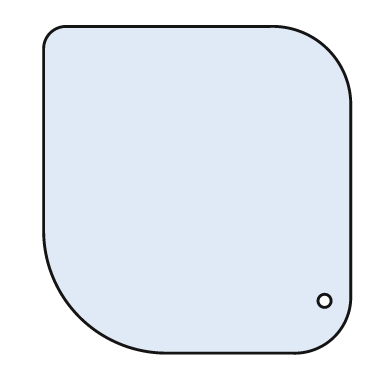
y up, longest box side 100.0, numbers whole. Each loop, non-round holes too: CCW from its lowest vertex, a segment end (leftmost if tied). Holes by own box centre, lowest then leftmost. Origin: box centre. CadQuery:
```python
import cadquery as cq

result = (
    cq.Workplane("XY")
    .moveTo(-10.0, -50.0)
    .lineTo(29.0, -50.0)
    .threePointArc((42.0, -45.0), (47.0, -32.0))
    .lineTo(47.0, 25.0)
    .threePointArc((40.0, 43.0), (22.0, 50.0))
    .lineTo(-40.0, 50.0)
    .threePointArc((-45.0, 48.0), (-47.0, 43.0))
    .lineTo(-47.0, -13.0)
    .threePointArc((-36.0, -39.0), (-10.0, -50.0))
    .close()
    .moveTo(39.0, -34.0)
    .circle(2.0)
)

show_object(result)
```